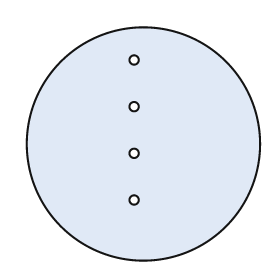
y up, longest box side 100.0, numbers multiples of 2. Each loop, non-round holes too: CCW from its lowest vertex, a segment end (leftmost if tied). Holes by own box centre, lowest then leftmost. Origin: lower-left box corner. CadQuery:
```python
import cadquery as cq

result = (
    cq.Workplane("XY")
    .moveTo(50.0, 50.0)
    .circle(50.0)
    .moveTo(46.0, 26.0)
    .circle(2.0)
    .moveTo(46.0, 46.0)
    .circle(2.0)
    .moveTo(46.0, 66.0)
    .circle(2.0)
    .moveTo(46.0, 86.0)
    .circle(2.0)
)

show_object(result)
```